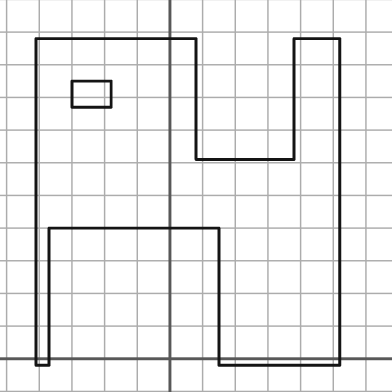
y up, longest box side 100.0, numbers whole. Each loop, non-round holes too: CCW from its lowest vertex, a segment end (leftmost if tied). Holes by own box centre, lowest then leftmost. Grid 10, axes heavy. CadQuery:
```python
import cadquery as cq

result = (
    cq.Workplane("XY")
    .moveTo(-41.0, -2.0)
    .lineTo(-37.0, -2.0)
    .lineTo(-37.0, 40.0)
    .lineTo(15.0, 40.0)
    .lineTo(15.0, -2.0)
    .lineTo(52.0, -2.0)
    .lineTo(52.0, 98.0)
    .lineTo(38.0, 98.0)
    .lineTo(38.0, 61.0)
    .lineTo(8.0, 61.0)
    .lineTo(8.0, 98.0)
    .lineTo(-41.0, 98.0)
    .close()
    .moveTo(-30.0, 77.0)
    .lineTo(-18.0, 77.0)
    .lineTo(-18.0, 85.0)
    .lineTo(-30.0, 85.0)
    .close()
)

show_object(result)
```